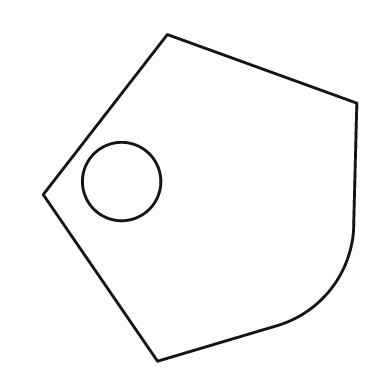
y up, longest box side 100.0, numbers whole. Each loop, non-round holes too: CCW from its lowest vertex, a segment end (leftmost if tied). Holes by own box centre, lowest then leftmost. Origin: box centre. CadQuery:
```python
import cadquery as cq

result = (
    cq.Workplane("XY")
    .moveTo(-13.0, -50.0)
    .lineTo(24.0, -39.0)
    .threePointArc((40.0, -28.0), (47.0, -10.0))
    .lineTo(48.0, 29.0)
    .lineTo(-10.0, 50.0)
    .lineTo(-48.0, 1.0)
    .close()
    .moveTo(-24.0, 5.0)
    .circle(12.0)
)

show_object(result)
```